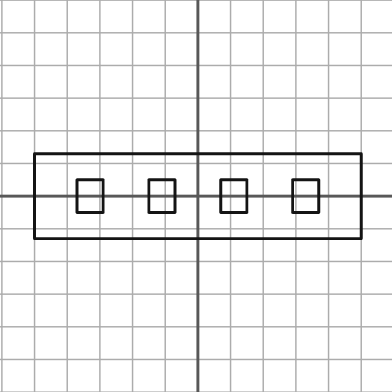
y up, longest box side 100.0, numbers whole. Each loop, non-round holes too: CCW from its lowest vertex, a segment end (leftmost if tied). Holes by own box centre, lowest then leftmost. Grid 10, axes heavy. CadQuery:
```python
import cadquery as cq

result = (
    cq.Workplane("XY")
    .moveTo(-50.0, -13.0)
    .lineTo(50.0, -13.0)
    .lineTo(50.0, 13.0)
    .lineTo(-50.0, 13.0)
    .close()
    .moveTo(-37.0, -5.0)
    .lineTo(-29.0, -5.0)
    .lineTo(-29.0, 5.0)
    .lineTo(-37.0, 5.0)
    .close()
    .moveTo(-15.0, -5.0)
    .lineTo(-7.0, -5.0)
    .lineTo(-7.0, 5.0)
    .lineTo(-15.0, 5.0)
    .close()
    .moveTo(7.0, -5.0)
    .lineTo(15.0, -5.0)
    .lineTo(15.0, 5.0)
    .lineTo(7.0, 5.0)
    .close()
    .moveTo(29.0, -5.0)
    .lineTo(37.0, -5.0)
    .lineTo(37.0, 5.0)
    .lineTo(29.0, 5.0)
    .close()
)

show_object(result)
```